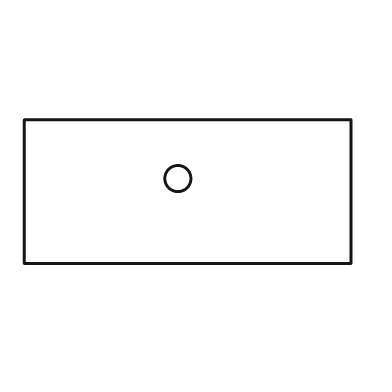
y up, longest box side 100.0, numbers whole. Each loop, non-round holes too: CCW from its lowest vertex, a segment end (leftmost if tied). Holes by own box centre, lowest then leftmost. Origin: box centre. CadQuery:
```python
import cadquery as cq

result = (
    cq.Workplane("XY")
    .moveTo(-50.0, -22.0)
    .lineTo(50.0, -22.0)
    .lineTo(50.0, 22.0)
    .lineTo(-50.0, 22.0)
    .close()
    .moveTo(-3.0, 4.0)
    .circle(4.0)
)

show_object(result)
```